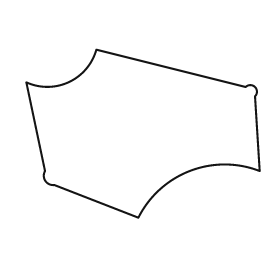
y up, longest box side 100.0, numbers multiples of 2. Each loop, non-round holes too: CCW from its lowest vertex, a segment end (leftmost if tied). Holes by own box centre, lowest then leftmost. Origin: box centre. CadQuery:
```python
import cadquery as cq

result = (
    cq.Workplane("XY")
    .moveTo(-2.0, -36.0)
    .threePointArc((20.0, -16.0), (50.0, -16.0))
    .lineTo(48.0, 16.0)
    .threePointArc((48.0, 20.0), (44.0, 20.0))
    .lineTo(-20.0, 36.0)
    .threePointArc((-32.0, 22.0), (-50.0, 22.0))
    .lineTo(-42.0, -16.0)
    .threePointArc((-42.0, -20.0), (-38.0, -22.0))
    .close()
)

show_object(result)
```